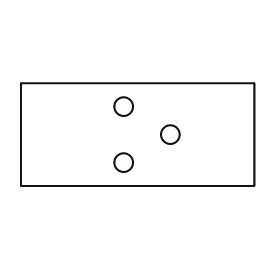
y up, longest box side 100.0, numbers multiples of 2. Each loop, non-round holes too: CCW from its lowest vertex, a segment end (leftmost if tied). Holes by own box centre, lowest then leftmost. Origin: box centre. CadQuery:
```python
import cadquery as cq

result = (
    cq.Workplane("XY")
    .moveTo(-50.0, -22.0)
    .lineTo(50.0, -22.0)
    .lineTo(50.0, 22.0)
    .lineTo(-50.0, 22.0)
    .close()
    .moveTo(-6.0, -12.0)
    .circle(4.0)
    .moveTo(14.0, 0.0)
    .circle(4.0)
    .moveTo(-6.0, 12.0)
    .circle(4.0)
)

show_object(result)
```